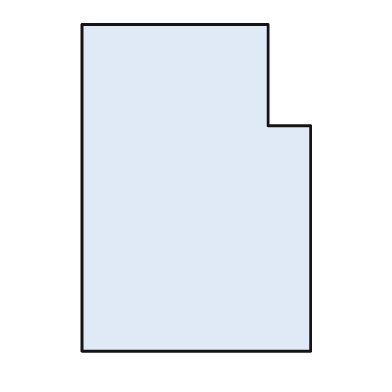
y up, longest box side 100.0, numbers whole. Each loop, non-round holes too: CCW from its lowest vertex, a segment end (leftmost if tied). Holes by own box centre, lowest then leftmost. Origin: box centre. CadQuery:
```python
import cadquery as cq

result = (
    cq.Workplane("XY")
    .moveTo(-35.0, -50.0)
    .lineTo(35.0, -50.0)
    .lineTo(35.0, 19.0)
    .lineTo(22.0, 19.0)
    .lineTo(22.0, 50.0)
    .lineTo(-35.0, 50.0)
    .close()
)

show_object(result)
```